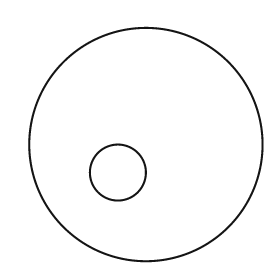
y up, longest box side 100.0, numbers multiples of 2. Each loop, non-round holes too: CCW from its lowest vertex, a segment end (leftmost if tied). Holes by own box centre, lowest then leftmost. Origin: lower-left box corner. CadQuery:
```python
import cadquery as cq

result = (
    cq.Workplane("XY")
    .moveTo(50.0, 50.0)
    .circle(50.0)
    .moveTo(38.0, 38.0)
    .circle(12.0)
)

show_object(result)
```